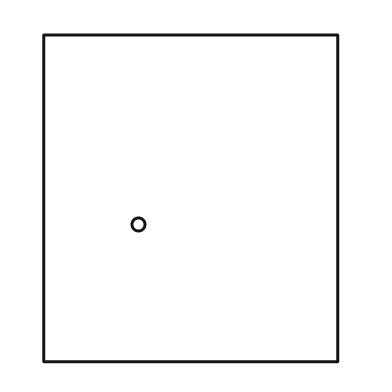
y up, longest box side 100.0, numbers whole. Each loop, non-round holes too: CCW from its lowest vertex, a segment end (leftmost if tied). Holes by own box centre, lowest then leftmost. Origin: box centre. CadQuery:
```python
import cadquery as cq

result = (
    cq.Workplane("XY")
    .moveTo(-45.0, -50.0)
    .lineTo(45.0, -50.0)
    .lineTo(45.0, 50.0)
    .lineTo(-45.0, 50.0)
    .close()
    .moveTo(-16.0, -8.0)
    .circle(2.0)
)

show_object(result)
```